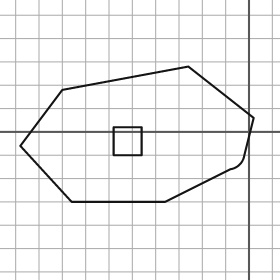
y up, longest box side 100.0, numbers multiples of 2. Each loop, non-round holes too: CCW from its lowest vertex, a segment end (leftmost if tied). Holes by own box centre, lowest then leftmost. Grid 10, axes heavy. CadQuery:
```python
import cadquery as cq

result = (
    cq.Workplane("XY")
    .moveTo(-76.0, -30.0)
    .lineTo(-36.0, -30.0)
    .lineTo(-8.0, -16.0)
    .threePointArc((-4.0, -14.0), (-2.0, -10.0))
    .lineTo(2.0, 6.0)
    .lineTo(-26.0, 28.0)
    .lineTo(-80.0, 18.0)
    .lineTo(-98.0, -6.0)
    .close()
    .moveTo(-58.0, -10.0)
    .lineTo(-46.0, -10.0)
    .lineTo(-46.0, 2.0)
    .lineTo(-58.0, 2.0)
    .close()
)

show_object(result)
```